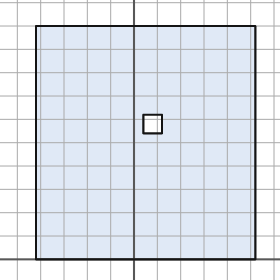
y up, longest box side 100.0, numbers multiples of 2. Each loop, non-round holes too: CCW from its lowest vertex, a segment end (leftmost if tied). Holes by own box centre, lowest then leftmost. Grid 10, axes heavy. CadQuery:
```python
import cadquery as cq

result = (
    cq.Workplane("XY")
    .moveTo(-42.0, 0.0)
    .lineTo(52.0, 0.0)
    .lineTo(52.0, 100.0)
    .lineTo(-42.0, 100.0)
    .close()
    .moveTo(4.0, 54.0)
    .lineTo(12.0, 54.0)
    .lineTo(12.0, 62.0)
    .lineTo(4.0, 62.0)
    .close()
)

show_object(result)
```